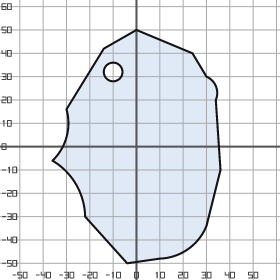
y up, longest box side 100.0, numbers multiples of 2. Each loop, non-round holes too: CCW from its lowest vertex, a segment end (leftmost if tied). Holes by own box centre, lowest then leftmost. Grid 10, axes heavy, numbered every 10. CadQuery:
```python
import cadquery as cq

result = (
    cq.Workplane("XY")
    .moveTo(-4.0, -50.0)
    .lineTo(10.0, -48.0)
    .threePointArc((22.0, -44.0), (30.0, -34.0))
    .lineTo(36.0, -10.0)
    .lineTo(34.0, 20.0)
    .threePointArc((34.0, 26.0), (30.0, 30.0))
    .lineTo(24.0, 40.0)
    .lineTo(0.0, 50.0)
    .lineTo(-14.0, 42.0)
    .lineTo(-30.0, 16.0)
    .threePointArc((-30.0, 4.0), (-36.0, -6.0))
    .threePointArc((-26.0, -16.0), (-22.0, -30.0))
    .close()
    .moveTo(-10.0, 32.0)
    .circle(4.0)
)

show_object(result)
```